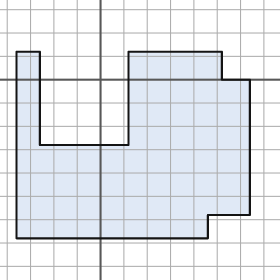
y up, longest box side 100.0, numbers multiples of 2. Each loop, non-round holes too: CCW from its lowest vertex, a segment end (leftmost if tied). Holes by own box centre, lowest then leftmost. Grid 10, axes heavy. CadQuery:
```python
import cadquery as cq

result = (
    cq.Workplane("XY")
    .moveTo(-36.0, -68.0)
    .lineTo(46.0, -68.0)
    .lineTo(46.0, -58.0)
    .lineTo(64.0, -58.0)
    .lineTo(64.0, 0.0)
    .lineTo(52.0, 0.0)
    .lineTo(52.0, 12.0)
    .lineTo(12.0, 12.0)
    .lineTo(12.0, -28.0)
    .lineTo(-26.0, -28.0)
    .lineTo(-26.0, 12.0)
    .lineTo(-36.0, 12.0)
    .close()
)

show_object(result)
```